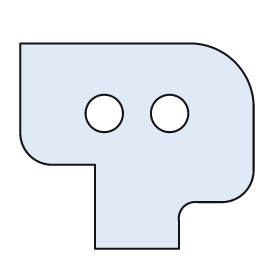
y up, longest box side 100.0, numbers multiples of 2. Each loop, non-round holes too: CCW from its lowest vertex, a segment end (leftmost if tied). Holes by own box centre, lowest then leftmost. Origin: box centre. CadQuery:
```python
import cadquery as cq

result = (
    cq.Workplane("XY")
    .moveTo(-18.0, -44.0)
    .lineTo(18.0, -44.0)
    .lineTo(18.0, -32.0)
    .threePointArc((20.0, -26.0), (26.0, -24.0))
    .lineTo(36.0, -24.0)
    .threePointArc((46.0, -20.0), (50.0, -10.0))
    .lineTo(50.0, 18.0)
    .threePointArc((42.0, 36.0), (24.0, 44.0))
    .lineTo(-50.0, 44.0)
    .lineTo(-50.0, 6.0)
    .threePointArc((-46.0, -4.0), (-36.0, -8.0))
    .lineTo(-18.0, -8.0)
    .close()
    .moveTo(-14.0, 14.0)
    .circle(8.0)
    .moveTo(14.0, 14.0)
    .circle(8.0)
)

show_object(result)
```